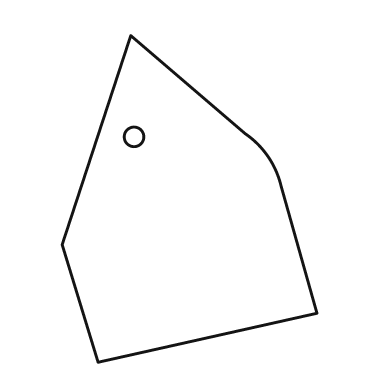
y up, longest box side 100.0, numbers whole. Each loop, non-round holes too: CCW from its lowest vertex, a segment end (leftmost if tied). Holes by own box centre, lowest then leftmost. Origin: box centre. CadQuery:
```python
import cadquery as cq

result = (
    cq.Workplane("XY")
    .moveTo(-28.0, -50.0)
    .lineTo(39.0, -35.0)
    .lineTo(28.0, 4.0)
    .threePointArc((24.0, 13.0), (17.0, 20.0))
    .lineTo(-18.0, 50.0)
    .lineTo(-39.0, -14.0)
    .close()
    .moveTo(-17.0, 19.0)
    .circle(3.0)
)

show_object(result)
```